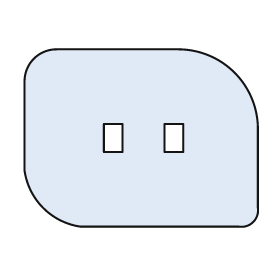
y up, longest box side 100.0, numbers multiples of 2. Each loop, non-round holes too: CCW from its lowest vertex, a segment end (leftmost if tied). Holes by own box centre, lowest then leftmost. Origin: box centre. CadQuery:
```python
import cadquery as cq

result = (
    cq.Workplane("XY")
    .moveTo(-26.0, -38.0)
    .lineTo(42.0, -38.0)
    .threePointArc((48.0, -36.0), (50.0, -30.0))
    .lineTo(50.0, 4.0)
    .threePointArc((40.0, 28.0), (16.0, 38.0))
    .lineTo(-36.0, 38.0)
    .threePointArc((-46.0, 34.0), (-50.0, 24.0))
    .lineTo(-50.0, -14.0)
    .threePointArc((-42.0, -30.0), (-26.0, -38.0))
    .close()
    .moveTo(-16.0, -6.0)
    .lineTo(-8.0, -6.0)
    .lineTo(-8.0, 6.0)
    .lineTo(-16.0, 6.0)
    .close()
    .moveTo(10.0, -6.0)
    .lineTo(18.0, -6.0)
    .lineTo(18.0, 6.0)
    .lineTo(10.0, 6.0)
    .close()
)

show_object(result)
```